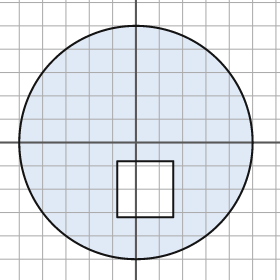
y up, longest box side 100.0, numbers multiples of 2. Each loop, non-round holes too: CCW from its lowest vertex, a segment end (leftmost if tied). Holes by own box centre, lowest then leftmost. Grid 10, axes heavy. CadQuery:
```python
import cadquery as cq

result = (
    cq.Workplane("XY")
    .moveTo(0.0, 0.0)
    .circle(50.0)
    .moveTo(-8.0, -32.0)
    .lineTo(16.0, -32.0)
    .lineTo(16.0, -8.0)
    .lineTo(-8.0, -8.0)
    .close()
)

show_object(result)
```